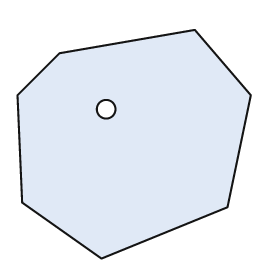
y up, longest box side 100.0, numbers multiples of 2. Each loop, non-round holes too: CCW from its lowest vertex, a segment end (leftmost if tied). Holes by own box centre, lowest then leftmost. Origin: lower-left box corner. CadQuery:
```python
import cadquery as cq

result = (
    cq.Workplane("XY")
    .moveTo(36.0, 0.0)
    .lineTo(90.0, 22.0)
    .lineTo(100.0, 70.0)
    .lineTo(76.0, 98.0)
    .lineTo(18.0, 88.0)
    .lineTo(0.0, 70.0)
    .lineTo(2.0, 24.0)
    .close()
    .moveTo(38.0, 64.0)
    .circle(4.0)
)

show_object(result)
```